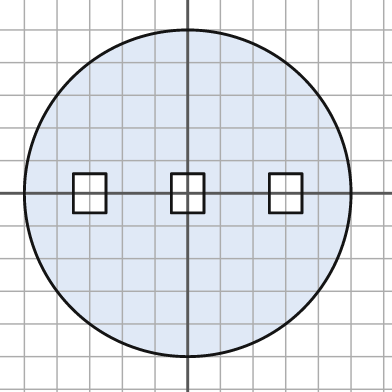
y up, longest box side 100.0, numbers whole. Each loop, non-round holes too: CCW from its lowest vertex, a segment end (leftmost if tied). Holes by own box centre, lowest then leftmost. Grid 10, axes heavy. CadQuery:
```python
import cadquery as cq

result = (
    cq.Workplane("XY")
    .moveTo(0.0, 0.0)
    .circle(50.0)
    .moveTo(-35.0, -6.0)
    .lineTo(-25.0, -6.0)
    .lineTo(-25.0, 6.0)
    .lineTo(-35.0, 6.0)
    .close()
    .moveTo(-5.0, -6.0)
    .lineTo(5.0, -6.0)
    .lineTo(5.0, 6.0)
    .lineTo(-5.0, 6.0)
    .close()
    .moveTo(25.0, -6.0)
    .lineTo(35.0, -6.0)
    .lineTo(35.0, 6.0)
    .lineTo(25.0, 6.0)
    .close()
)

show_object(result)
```